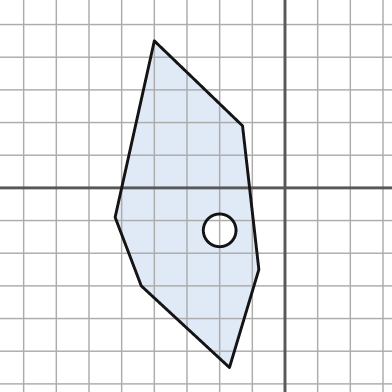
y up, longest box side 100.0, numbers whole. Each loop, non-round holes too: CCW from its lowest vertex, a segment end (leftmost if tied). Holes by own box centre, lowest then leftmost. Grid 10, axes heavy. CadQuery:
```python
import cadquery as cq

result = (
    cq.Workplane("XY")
    .moveTo(-17.0, -55.0)
    .lineTo(-8.0, -25.0)
    .lineTo(-13.0, 19.0)
    .lineTo(-40.0, 45.0)
    .lineTo(-52.0, -9.0)
    .lineTo(-44.0, -30.0)
    .close()
    .moveTo(-20.0, -13.0)
    .circle(5.0)
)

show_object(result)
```